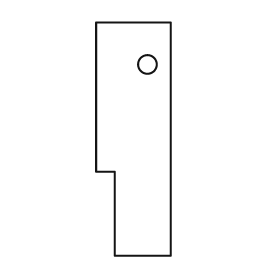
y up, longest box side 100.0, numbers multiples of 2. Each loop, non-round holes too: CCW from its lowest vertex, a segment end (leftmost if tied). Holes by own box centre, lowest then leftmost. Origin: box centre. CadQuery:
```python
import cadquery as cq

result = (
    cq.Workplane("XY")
    .moveTo(-8.0, -50.0)
    .lineTo(16.0, -50.0)
    .lineTo(16.0, 50.0)
    .lineTo(-16.0, 50.0)
    .lineTo(-16.0, -14.0)
    .lineTo(-8.0, -14.0)
    .close()
    .moveTo(6.0, 32.0)
    .circle(4.0)
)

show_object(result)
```